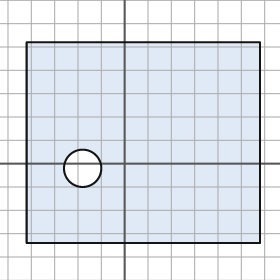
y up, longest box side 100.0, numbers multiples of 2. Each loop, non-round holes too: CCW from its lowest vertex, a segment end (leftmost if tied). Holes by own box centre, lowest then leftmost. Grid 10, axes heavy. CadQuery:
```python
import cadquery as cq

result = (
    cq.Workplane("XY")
    .moveTo(-42.0, -34.0)
    .lineTo(58.0, -34.0)
    .lineTo(58.0, 52.0)
    .lineTo(-42.0, 52.0)
    .close()
    .moveTo(-18.0, -2.0)
    .circle(8.0)
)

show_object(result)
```